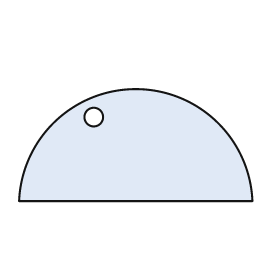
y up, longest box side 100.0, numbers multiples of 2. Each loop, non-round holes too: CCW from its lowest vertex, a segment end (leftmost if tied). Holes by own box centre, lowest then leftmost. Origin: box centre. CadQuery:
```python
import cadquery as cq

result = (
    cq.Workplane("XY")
    .moveTo(-50.0, -24.0)
    .lineTo(50.0, -24.0)
    .threePointArc((0.0, 24.0), (-50.0, -24.0))
    .close()
    .moveTo(-18.0, 12.0)
    .circle(4.0)
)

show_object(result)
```